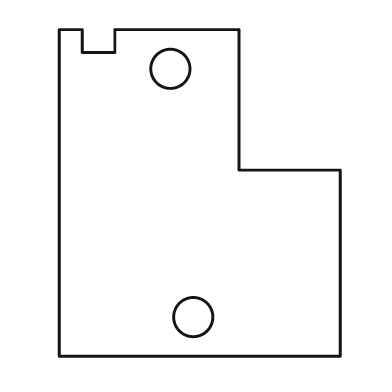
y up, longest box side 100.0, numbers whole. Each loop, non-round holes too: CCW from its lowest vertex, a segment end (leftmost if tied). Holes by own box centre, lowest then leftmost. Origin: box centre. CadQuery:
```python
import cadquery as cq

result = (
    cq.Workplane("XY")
    .moveTo(-43.0, -50.0)
    .lineTo(43.0, -50.0)
    .lineTo(43.0, 7.0)
    .lineTo(12.0, 7.0)
    .lineTo(12.0, 50.0)
    .lineTo(-26.0, 50.0)
    .lineTo(-26.0, 43.0)
    .lineTo(-36.0, 43.0)
    .lineTo(-36.0, 50.0)
    .lineTo(-43.0, 50.0)
    .close()
    .moveTo(-2.0, -38.0)
    .circle(6.0)
    .moveTo(-9.0, 38.0)
    .circle(6.0)
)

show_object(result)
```